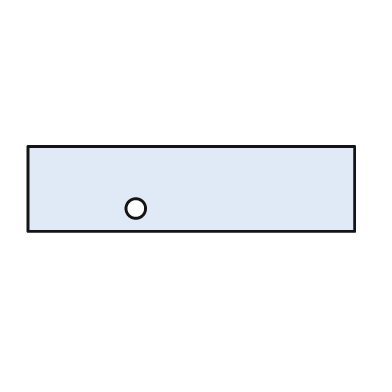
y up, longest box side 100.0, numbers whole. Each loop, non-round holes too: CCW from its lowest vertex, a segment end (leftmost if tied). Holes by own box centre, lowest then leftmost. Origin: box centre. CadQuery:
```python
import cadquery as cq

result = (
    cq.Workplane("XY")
    .moveTo(-50.0, -13.0)
    .lineTo(50.0, -13.0)
    .lineTo(50.0, 13.0)
    .lineTo(-50.0, 13.0)
    .close()
    .moveTo(-17.0, -6.0)
    .circle(3.0)
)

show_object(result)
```